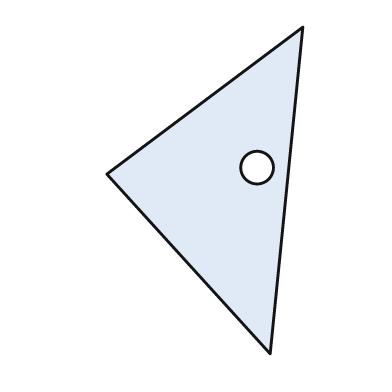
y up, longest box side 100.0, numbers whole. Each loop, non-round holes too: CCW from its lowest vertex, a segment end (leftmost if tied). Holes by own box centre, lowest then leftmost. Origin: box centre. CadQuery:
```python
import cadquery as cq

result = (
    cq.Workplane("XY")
    .moveTo(20.0, -50.0)
    .lineTo(30.0, 50.0)
    .lineTo(-30.0, 5.0)
    .close()
    .moveTo(16.0, 7.0)
    .circle(5.0)
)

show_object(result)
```